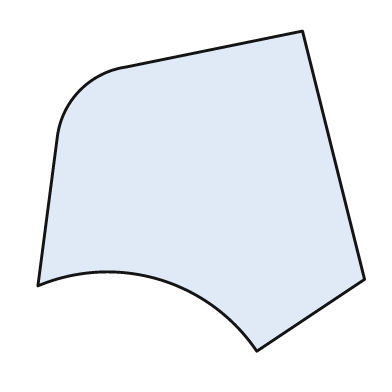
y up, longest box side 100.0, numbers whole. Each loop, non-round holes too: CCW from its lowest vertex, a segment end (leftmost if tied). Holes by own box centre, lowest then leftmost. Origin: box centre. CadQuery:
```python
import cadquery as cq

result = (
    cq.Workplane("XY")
    .moveTo(17.0, -49.0)
    .lineTo(50.0, -27.0)
    .lineTo(31.0, 49.0)
    .lineTo(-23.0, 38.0)
    .threePointArc((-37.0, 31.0), (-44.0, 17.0))
    .lineTo(-50.0, -29.0)
    .threePointArc((-13.0, -27.0), (17.0, -49.0))
    .close()
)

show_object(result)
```